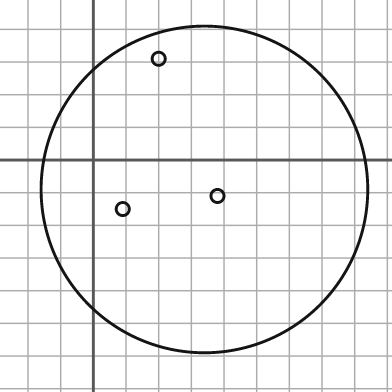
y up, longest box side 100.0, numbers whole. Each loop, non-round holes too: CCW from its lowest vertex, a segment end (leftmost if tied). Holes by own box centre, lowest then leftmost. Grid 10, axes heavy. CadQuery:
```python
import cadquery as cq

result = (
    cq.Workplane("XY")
    .moveTo(34.0, -9.0)
    .circle(50.0)
    .moveTo(9.0, -15.0)
    .circle(2.0)
    .moveTo(38.0, -11.0)
    .circle(2.0)
    .moveTo(20.0, 31.0)
    .circle(2.0)
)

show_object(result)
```